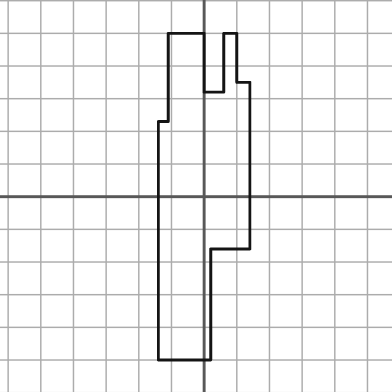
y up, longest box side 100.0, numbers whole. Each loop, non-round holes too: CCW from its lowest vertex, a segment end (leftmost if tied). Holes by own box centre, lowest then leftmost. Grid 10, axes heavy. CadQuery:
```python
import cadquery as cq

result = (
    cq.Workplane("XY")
    .moveTo(-14.0, -50.0)
    .lineTo(2.0, -50.0)
    .lineTo(2.0, -16.0)
    .lineTo(14.0, -16.0)
    .lineTo(14.0, 35.0)
    .lineTo(10.0, 35.0)
    .lineTo(10.0, 50.0)
    .lineTo(6.0, 50.0)
    .lineTo(6.0, 32.0)
    .lineTo(0.0, 32.0)
    .lineTo(0.0, 50.0)
    .lineTo(-11.0, 50.0)
    .lineTo(-11.0, 23.0)
    .lineTo(-14.0, 23.0)
    .close()
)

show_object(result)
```